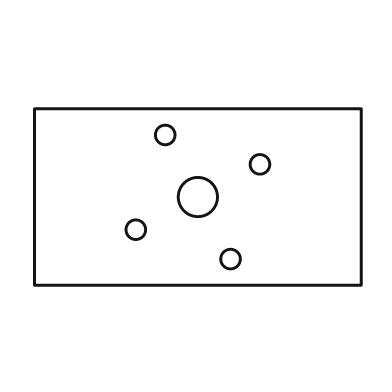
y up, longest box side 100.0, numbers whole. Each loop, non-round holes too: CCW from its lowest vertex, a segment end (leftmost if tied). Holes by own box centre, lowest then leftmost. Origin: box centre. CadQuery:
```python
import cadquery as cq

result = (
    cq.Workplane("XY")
    .moveTo(-50.0, -27.0)
    .lineTo(50.0, -27.0)
    .lineTo(50.0, 27.0)
    .lineTo(-50.0, 27.0)
    .close()
    .moveTo(10.0, -19.0)
    .circle(3.0)
    .moveTo(-19.0, -10.0)
    .circle(3.0)
    .moveTo(0.0, 0.0)
    .circle(6.0)
    .moveTo(19.0, 10.0)
    .circle(3.0)
    .moveTo(-10.0, 19.0)
    .circle(3.0)
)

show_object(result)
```